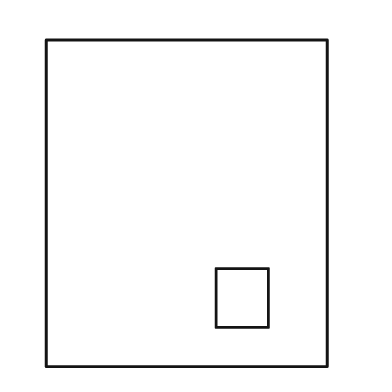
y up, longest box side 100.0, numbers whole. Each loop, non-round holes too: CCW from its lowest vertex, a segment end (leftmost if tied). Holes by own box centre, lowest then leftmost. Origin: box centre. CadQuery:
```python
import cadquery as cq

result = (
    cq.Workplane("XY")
    .moveTo(-43.0, -50.0)
    .lineTo(43.0, -50.0)
    .lineTo(43.0, 50.0)
    .lineTo(-43.0, 50.0)
    .close()
    .moveTo(9.0, -38.0)
    .lineTo(25.0, -38.0)
    .lineTo(25.0, -20.0)
    .lineTo(9.0, -20.0)
    .close()
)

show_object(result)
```